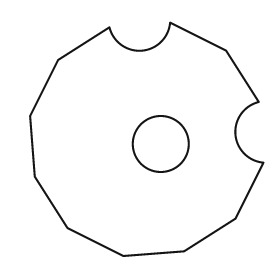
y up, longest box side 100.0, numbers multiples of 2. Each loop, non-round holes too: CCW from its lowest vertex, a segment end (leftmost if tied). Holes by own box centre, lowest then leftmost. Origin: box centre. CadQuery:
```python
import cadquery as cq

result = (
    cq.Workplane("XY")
    .moveTo(-10.0, -50.0)
    .lineTo(16.0, -48.0)
    .lineTo(38.0, -34.0)
    .lineTo(50.0, -10.0)
    .threePointArc((38.0, 2.0), (48.0, 16.0))
    .lineTo(34.0, 38.0)
    .lineTo(10.0, 50.0)
    .threePointArc((-2.0, 38.0), (-16.0, 48.0))
    .lineTo(-38.0, 34.0)
    .lineTo(-50.0, 10.0)
    .lineTo(-48.0, -16.0)
    .lineTo(-34.0, -38.0)
    .close()
    .moveTo(6.0, -2.0)
    .circle(12.0)
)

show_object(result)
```